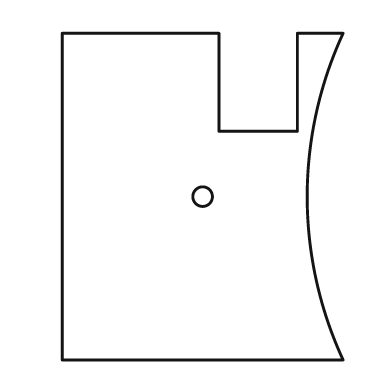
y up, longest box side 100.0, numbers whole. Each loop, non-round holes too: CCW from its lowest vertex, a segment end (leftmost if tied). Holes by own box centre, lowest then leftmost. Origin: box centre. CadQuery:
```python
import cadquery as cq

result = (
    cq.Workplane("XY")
    .moveTo(-43.0, -50.0)
    .lineTo(43.0, -50.0)
    .threePointArc((32.0, 0.0), (43.0, 50.0))
    .lineTo(29.0, 50.0)
    .lineTo(29.0, 20.0)
    .lineTo(5.0, 20.0)
    .lineTo(5.0, 50.0)
    .lineTo(-43.0, 50.0)
    .close()
    .moveTo(0.0, 0.0)
    .circle(3.0)
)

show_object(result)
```